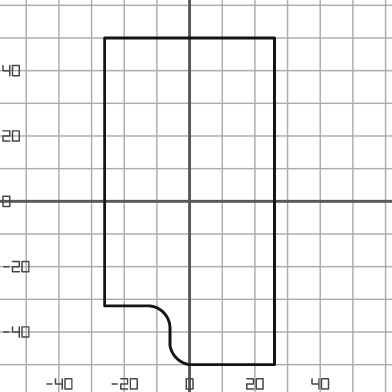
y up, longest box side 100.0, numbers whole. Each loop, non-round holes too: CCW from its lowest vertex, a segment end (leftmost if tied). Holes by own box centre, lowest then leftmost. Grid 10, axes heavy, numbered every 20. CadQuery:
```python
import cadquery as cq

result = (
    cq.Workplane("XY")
    .moveTo(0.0, -50.0)
    .lineTo(26.0, -50.0)
    .lineTo(26.0, 50.0)
    .lineTo(-26.0, 50.0)
    .lineTo(-26.0, -32.0)
    .lineTo(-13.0, -32.0)
    .threePointArc((-8.0, -34.0), (-6.0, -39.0))
    .lineTo(-6.0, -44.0)
    .threePointArc((-4.0, -48.0), (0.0, -50.0))
    .close()
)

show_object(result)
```